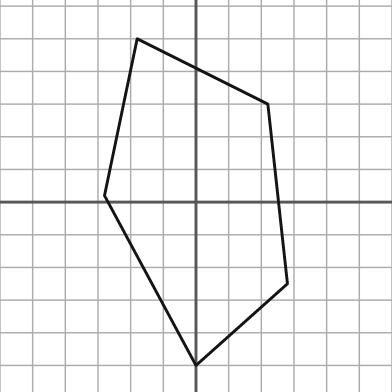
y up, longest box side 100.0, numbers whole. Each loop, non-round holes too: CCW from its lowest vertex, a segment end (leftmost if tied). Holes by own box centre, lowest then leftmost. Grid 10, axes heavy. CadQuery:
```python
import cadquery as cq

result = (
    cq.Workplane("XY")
    .moveTo(0.0, -50.0)
    .lineTo(28.0, -25.0)
    .lineTo(22.0, 30.0)
    .lineTo(-18.0, 50.0)
    .lineTo(-28.0, 2.0)
    .close()
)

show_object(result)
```